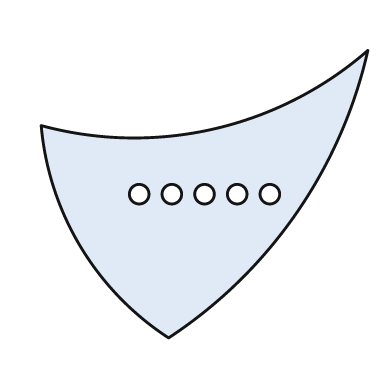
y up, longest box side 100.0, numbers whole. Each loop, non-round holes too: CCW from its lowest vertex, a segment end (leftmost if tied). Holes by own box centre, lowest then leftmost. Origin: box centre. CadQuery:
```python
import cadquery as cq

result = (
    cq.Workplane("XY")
    .moveTo(-11.0, -44.0)
    .threePointArc((28.0, -6.0), (50.0, 44.0))
    .threePointArc((3.0, 20.0), (-50.0, 21.0))
    .threePointArc((-38.0, -16.0), (-11.0, -44.0))
    .close()
    .moveTo(-20.0, 0.0)
    .circle(3.0)
    .moveTo(-10.0, 0.0)
    .circle(3.0)
    .moveTo(0.0, 0.0)
    .circle(3.0)
    .moveTo(10.0, 0.0)
    .circle(3.0)
    .moveTo(20.0, 0.0)
    .circle(3.0)
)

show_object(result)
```